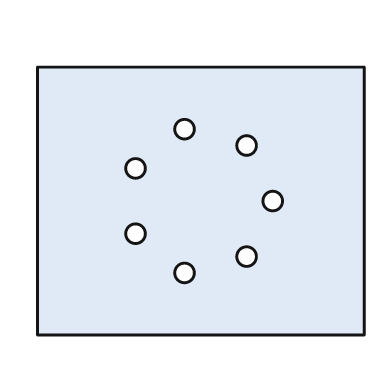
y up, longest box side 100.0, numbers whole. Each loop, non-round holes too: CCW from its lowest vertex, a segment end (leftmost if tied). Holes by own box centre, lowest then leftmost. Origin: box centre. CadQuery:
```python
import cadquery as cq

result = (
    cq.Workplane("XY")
    .moveTo(-50.0, -41.0)
    .lineTo(50.0, -41.0)
    .lineTo(50.0, 41.0)
    .lineTo(-50.0, 41.0)
    .close()
    .moveTo(-5.0, -22.0)
    .circle(3.0)
    .moveTo(14.0, -17.0)
    .circle(3.0)
    .moveTo(-20.0, -10.0)
    .circle(3.0)
    .moveTo(22.0, 0.0)
    .circle(3.0)
    .moveTo(-20.0, 10.0)
    .circle(3.0)
    .moveTo(14.0, 17.0)
    .circle(3.0)
    .moveTo(-5.0, 22.0)
    .circle(3.0)
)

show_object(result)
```